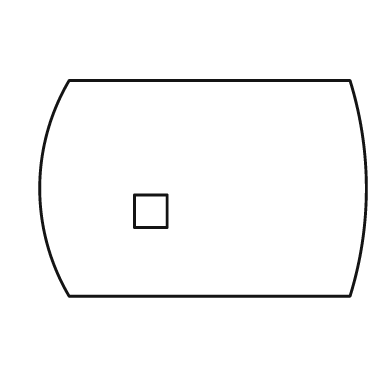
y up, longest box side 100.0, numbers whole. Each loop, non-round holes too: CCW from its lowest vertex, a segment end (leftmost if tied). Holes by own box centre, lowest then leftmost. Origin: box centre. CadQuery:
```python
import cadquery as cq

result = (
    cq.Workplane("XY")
    .moveTo(-41.0, -33.0)
    .lineTo(45.0, -33.0)
    .threePointArc((50.0, 0.0), (45.0, 33.0))
    .lineTo(-41.0, 33.0)
    .threePointArc((-50.0, 0.0), (-41.0, -33.0))
    .close()
    .moveTo(-21.0, -12.0)
    .lineTo(-11.0, -12.0)
    .lineTo(-11.0, -2.0)
    .lineTo(-21.0, -2.0)
    .close()
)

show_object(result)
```